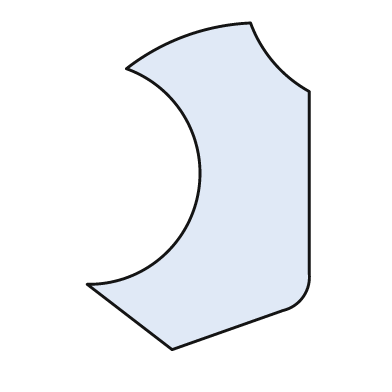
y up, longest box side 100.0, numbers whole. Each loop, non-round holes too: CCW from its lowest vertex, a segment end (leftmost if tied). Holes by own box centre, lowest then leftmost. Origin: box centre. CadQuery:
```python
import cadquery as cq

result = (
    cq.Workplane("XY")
    .moveTo(-8.0, -50.0)
    .lineTo(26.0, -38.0)
    .threePointArc((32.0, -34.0), (34.0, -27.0))
    .lineTo(34.0, 29.0)
    .threePointArc((23.0, 38.0), (16.0, 50.0))
    .threePointArc((-4.0, 46.0), (-22.0, 36.0))
    .threePointArc((0.0, -2.0), (-34.0, -30.0))
    .close()
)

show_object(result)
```